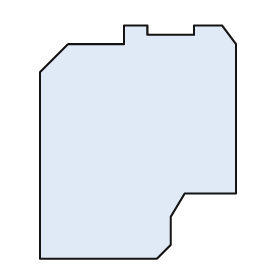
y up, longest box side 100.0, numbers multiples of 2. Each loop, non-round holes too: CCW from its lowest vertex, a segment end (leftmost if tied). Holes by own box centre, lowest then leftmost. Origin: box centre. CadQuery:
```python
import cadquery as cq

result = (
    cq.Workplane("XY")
    .moveTo(-42.0, -50.0)
    .lineTo(8.0, -50.0)
    .lineTo(14.0, -44.0)
    .lineTo(14.0, -32.0)
    .lineTo(20.0, -22.0)
    .lineTo(42.0, -22.0)
    .lineTo(42.0, 42.0)
    .lineTo(36.0, 50.0)
    .lineTo(24.0, 50.0)
    .lineTo(24.0, 46.0)
    .lineTo(4.0, 46.0)
    .lineTo(4.0, 50.0)
    .lineTo(-6.0, 50.0)
    .lineTo(-6.0, 42.0)
    .lineTo(-30.0, 42.0)
    .lineTo(-42.0, 30.0)
    .close()
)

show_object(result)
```